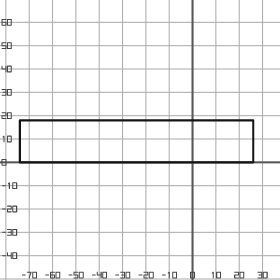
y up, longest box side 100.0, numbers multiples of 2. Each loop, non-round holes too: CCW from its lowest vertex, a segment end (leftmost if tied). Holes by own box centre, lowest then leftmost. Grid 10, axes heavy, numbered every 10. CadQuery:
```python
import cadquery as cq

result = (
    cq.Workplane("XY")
    .moveTo(-74.0, 0.0)
    .lineTo(26.0, 0.0)
    .lineTo(26.0, 18.0)
    .lineTo(-74.0, 18.0)
    .close()
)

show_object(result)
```